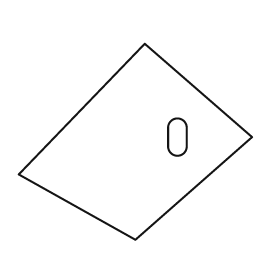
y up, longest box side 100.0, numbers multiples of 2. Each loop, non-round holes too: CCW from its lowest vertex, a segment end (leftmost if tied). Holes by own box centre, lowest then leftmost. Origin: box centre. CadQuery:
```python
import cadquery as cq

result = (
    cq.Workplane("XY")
    .moveTo(0.0, -42.0)
    .lineTo(50.0, 2.0)
    .lineTo(4.0, 42.0)
    .lineTo(-50.0, -14.0)
    .close()
    .moveTo(14.0, -2.0)
    .threePointArc((18.0, -6.0), (22.0, -2.0))
    .lineTo(22.0, 6.0)
    .threePointArc((18.0, 10.0), (14.0, 6.0))
    .close()
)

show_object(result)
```